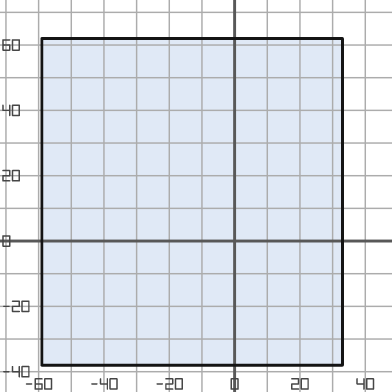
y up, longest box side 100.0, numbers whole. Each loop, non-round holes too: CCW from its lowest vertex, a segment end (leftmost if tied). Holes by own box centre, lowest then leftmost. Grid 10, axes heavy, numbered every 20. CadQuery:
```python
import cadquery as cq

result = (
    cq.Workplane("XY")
    .moveTo(-59.0, -38.0)
    .lineTo(33.0, -38.0)
    .lineTo(33.0, 62.0)
    .lineTo(-59.0, 62.0)
    .close()
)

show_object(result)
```